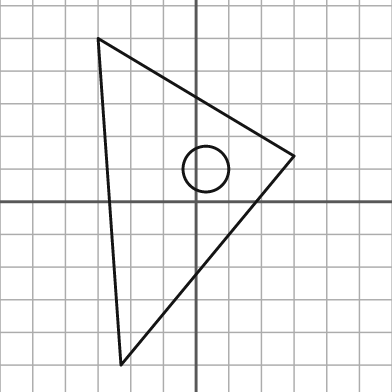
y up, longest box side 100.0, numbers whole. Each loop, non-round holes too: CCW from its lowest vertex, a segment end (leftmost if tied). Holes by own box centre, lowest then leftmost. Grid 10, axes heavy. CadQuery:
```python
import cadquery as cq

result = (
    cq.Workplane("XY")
    .moveTo(-23.0, -50.0)
    .lineTo(30.0, 14.0)
    .lineTo(-30.0, 50.0)
    .close()
    .moveTo(3.0, 10.0)
    .circle(7.0)
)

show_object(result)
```